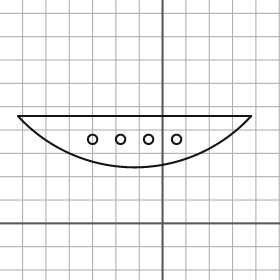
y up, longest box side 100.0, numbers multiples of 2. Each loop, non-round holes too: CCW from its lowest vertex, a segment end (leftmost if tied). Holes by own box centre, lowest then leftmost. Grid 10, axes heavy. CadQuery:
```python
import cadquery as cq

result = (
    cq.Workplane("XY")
    .moveTo(-62.0, 46.0)
    .threePointArc((-12.0, 24.0), (38.0, 46.0))
    .close()
    .moveTo(-30.0, 36.0)
    .circle(2.0)
    .moveTo(-18.0, 36.0)
    .circle(2.0)
    .moveTo(-6.0, 36.0)
    .circle(2.0)
    .moveTo(6.0, 36.0)
    .circle(2.0)
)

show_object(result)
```